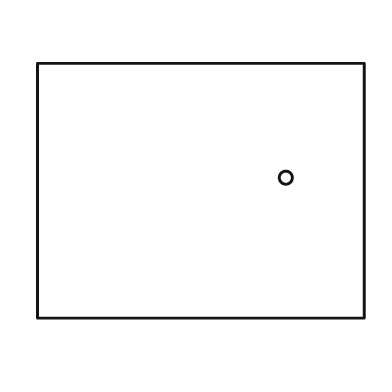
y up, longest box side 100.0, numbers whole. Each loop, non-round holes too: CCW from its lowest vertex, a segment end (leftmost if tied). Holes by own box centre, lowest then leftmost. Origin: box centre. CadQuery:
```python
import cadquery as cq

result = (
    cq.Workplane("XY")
    .moveTo(-50.0, -39.0)
    .lineTo(50.0, -39.0)
    .lineTo(50.0, 39.0)
    .lineTo(-50.0, 39.0)
    .close()
    .moveTo(26.0, 4.0)
    .circle(2.0)
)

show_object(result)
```